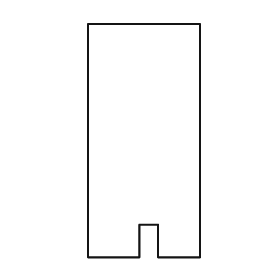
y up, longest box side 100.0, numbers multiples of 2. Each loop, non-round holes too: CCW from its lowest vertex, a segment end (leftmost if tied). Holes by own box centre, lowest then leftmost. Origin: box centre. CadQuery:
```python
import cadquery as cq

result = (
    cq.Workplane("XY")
    .moveTo(-24.0, -50.0)
    .lineTo(-2.0, -50.0)
    .lineTo(-2.0, -36.0)
    .lineTo(6.0, -36.0)
    .lineTo(6.0, -50.0)
    .lineTo(24.0, -50.0)
    .lineTo(24.0, 50.0)
    .lineTo(-24.0, 50.0)
    .close()
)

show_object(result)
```